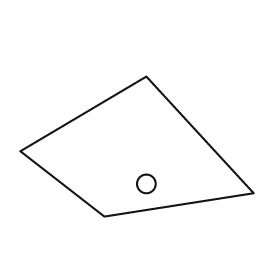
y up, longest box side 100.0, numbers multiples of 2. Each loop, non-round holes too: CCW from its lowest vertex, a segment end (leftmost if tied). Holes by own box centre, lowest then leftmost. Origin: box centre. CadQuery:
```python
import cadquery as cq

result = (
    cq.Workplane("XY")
    .moveTo(-14.0, -30.0)
    .lineTo(50.0, -20.0)
    .lineTo(4.0, 30.0)
    .lineTo(-50.0, -2.0)
    .close()
    .moveTo(4.0, -16.0)
    .circle(4.0)
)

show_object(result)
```